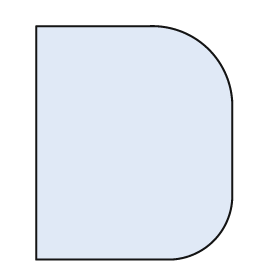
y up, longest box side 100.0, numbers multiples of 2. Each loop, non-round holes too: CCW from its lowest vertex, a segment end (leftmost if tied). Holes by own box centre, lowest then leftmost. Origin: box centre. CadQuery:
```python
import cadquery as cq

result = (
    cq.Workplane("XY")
    .moveTo(-42.0, -50.0)
    .lineTo(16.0, -50.0)
    .threePointArc((34.0, -42.0), (42.0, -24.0))
    .lineTo(42.0, 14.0)
    .threePointArc((32.0, 40.0), (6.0, 50.0))
    .lineTo(-42.0, 50.0)
    .close()
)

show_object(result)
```